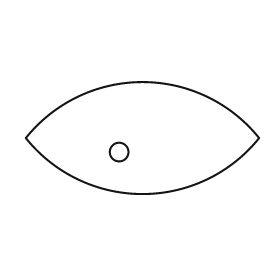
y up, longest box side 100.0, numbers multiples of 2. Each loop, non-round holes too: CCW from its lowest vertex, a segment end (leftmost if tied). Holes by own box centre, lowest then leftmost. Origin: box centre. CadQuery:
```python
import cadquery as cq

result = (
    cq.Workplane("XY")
    .moveTo(-50.0, 0.0)
    .threePointArc((0.0, -24.0), (50.0, 0.0))
    .threePointArc((0.0, 24.0), (-50.0, 0.0))
    .close()
    .moveTo(-10.0, -6.0)
    .circle(4.0)
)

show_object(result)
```